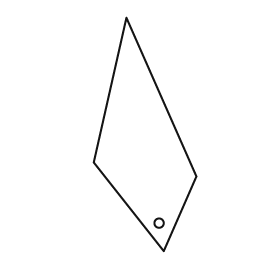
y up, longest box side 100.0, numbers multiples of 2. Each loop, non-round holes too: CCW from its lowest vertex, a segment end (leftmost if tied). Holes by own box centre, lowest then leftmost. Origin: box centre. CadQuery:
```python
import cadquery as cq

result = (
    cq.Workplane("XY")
    .moveTo(8.0, -50.0)
    .lineTo(22.0, -18.0)
    .lineTo(-8.0, 50.0)
    .lineTo(-22.0, -12.0)
    .close()
    .moveTo(6.0, -38.0)
    .circle(2.0)
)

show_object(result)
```